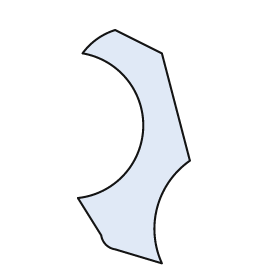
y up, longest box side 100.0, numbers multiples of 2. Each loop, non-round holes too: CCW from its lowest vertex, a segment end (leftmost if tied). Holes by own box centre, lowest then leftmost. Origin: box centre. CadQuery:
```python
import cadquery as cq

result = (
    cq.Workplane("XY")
    .moveTo(12.0, -50.0)
    .threePointArc((10.0, -26.0), (24.0, -6.0))
    .lineTo(12.0, 40.0)
    .lineTo(-8.0, 50.0)
    .threePointArc((-16.0, 46.0), (-22.0, 40.0))
    .threePointArc((4.0, 8.0), (-24.0, -22.0))
    .lineTo(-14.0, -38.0)
    .threePointArc((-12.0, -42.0), (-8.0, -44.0))
    .close()
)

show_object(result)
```